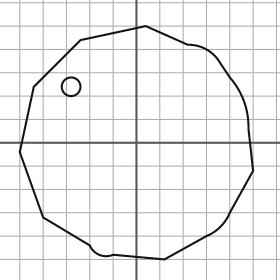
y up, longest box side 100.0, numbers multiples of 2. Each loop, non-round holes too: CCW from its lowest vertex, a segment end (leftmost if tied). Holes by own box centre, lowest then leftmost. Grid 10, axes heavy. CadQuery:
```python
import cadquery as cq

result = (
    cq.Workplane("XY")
    .moveTo(12.0, -50.0)
    .lineTo(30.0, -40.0)
    .threePointArc((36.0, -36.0), (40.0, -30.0))
    .lineTo(50.0, -12.0)
    .lineTo(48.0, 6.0)
    .threePointArc((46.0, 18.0), (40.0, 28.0))
    .lineTo(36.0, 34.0)
    .threePointArc((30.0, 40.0), (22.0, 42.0))
    .lineTo(4.0, 50.0)
    .lineTo(-24.0, 44.0)
    .lineTo(-44.0, 24.0)
    .lineTo(-50.0, -4.0)
    .lineTo(-40.0, -32.0)
    .lineTo(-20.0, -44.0)
    .threePointArc((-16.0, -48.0), (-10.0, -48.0))
    .close()
    .moveTo(-28.0, 24.0)
    .circle(4.0)
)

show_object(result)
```